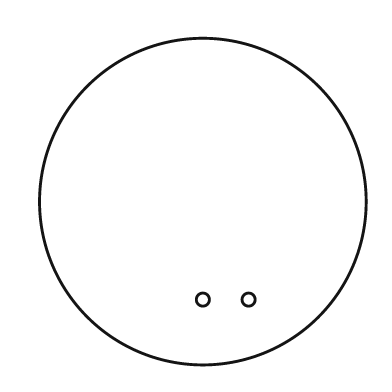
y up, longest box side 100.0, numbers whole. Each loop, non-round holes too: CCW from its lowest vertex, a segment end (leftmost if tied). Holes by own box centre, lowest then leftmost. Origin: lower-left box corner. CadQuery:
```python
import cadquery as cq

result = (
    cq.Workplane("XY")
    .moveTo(50.0, 50.0)
    .circle(50.0)
    .moveTo(50.0, 20.0)
    .circle(2.0)
    .moveTo(64.0, 20.0)
    .circle(2.0)
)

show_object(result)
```